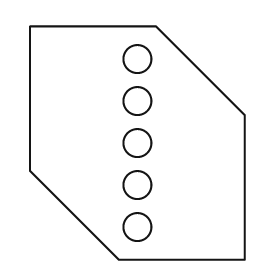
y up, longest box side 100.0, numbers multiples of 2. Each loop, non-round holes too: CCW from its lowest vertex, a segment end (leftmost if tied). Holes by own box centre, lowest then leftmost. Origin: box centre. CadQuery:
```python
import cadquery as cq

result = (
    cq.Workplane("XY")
    .moveTo(-8.0, -50.0)
    .lineTo(46.0, -50.0)
    .lineTo(46.0, 12.0)
    .lineTo(8.0, 50.0)
    .lineTo(-46.0, 50.0)
    .lineTo(-46.0, -12.0)
    .close()
    .moveTo(0.0, -36.0)
    .circle(6.0)
    .moveTo(0.0, -18.0)
    .circle(6.0)
    .moveTo(0.0, 0.0)
    .circle(6.0)
    .moveTo(0.0, 18.0)
    .circle(6.0)
    .moveTo(0.0, 36.0)
    .circle(6.0)
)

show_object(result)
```